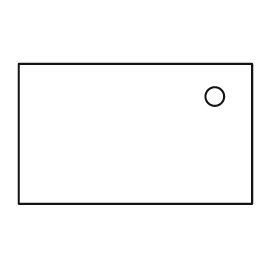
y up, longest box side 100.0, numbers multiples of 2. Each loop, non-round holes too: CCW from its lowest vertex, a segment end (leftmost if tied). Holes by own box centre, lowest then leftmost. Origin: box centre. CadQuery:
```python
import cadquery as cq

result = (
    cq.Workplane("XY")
    .moveTo(-50.0, -30.0)
    .lineTo(50.0, -30.0)
    .lineTo(50.0, 30.0)
    .lineTo(-50.0, 30.0)
    .close()
    .moveTo(34.0, 16.0)
    .circle(4.0)
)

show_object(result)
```